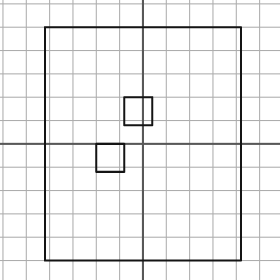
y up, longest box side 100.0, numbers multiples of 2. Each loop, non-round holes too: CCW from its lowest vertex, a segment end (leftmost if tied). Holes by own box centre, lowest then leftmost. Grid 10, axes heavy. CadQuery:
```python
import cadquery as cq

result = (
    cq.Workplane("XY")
    .moveTo(-42.0, -50.0)
    .lineTo(42.0, -50.0)
    .lineTo(42.0, 50.0)
    .lineTo(-42.0, 50.0)
    .close()
    .moveTo(-20.0, -12.0)
    .lineTo(-8.0, -12.0)
    .lineTo(-8.0, 0.0)
    .lineTo(-20.0, 0.0)
    .close()
    .moveTo(-8.0, 8.0)
    .lineTo(4.0, 8.0)
    .lineTo(4.0, 20.0)
    .lineTo(-8.0, 20.0)
    .close()
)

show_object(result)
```